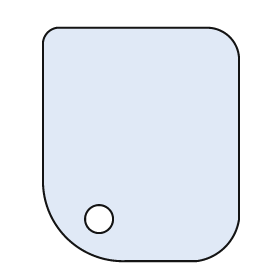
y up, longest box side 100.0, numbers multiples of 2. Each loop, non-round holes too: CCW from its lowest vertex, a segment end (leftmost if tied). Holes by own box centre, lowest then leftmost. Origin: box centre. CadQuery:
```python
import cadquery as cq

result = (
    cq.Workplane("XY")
    .moveTo(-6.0, -50.0)
    .lineTo(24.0, -50.0)
    .threePointArc((36.0, -44.0), (42.0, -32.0))
    .lineTo(42.0, 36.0)
    .threePointArc((38.0, 46.0), (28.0, 50.0))
    .lineTo(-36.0, 50.0)
    .threePointArc((-40.0, 48.0), (-42.0, 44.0))
    .lineTo(-42.0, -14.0)
    .threePointArc((-32.0, -40.0), (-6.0, -50.0))
    .close()
    .moveTo(-18.0, -32.0)
    .circle(6.0)
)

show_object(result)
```